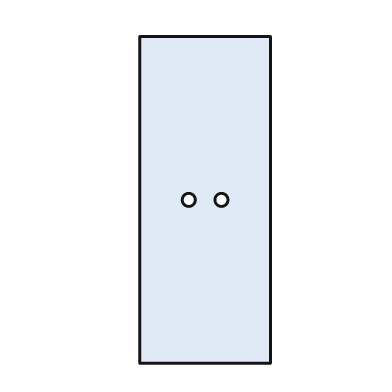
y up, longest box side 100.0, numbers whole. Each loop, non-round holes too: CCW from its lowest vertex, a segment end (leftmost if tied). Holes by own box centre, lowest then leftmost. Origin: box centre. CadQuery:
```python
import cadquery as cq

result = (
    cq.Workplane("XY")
    .moveTo(-20.0, -50.0)
    .lineTo(20.0, -50.0)
    .lineTo(20.0, 50.0)
    .lineTo(-20.0, 50.0)
    .close()
    .moveTo(-5.0, 0.0)
    .circle(2.0)
    .moveTo(5.0, 0.0)
    .circle(2.0)
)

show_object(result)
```